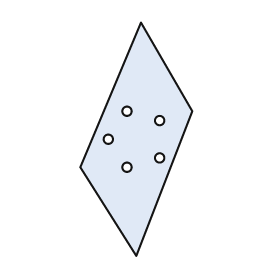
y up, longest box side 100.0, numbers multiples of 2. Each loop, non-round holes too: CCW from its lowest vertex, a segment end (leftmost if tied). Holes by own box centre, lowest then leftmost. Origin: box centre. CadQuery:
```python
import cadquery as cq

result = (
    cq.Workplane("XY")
    .moveTo(0.0, -50.0)
    .lineTo(24.0, 12.0)
    .lineTo(2.0, 50.0)
    .lineTo(-24.0, -12.0)
    .close()
    .moveTo(-4.0, -12.0)
    .circle(2.0)
    .moveTo(10.0, -8.0)
    .circle(2.0)
    .moveTo(-12.0, 0.0)
    .circle(2.0)
    .moveTo(10.0, 8.0)
    .circle(2.0)
    .moveTo(-4.0, 12.0)
    .circle(2.0)
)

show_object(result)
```